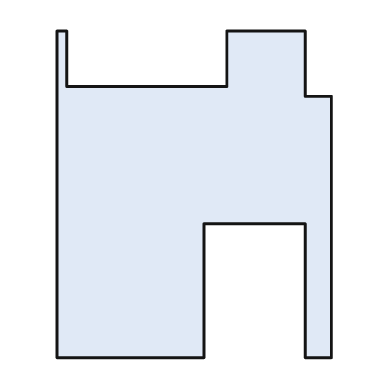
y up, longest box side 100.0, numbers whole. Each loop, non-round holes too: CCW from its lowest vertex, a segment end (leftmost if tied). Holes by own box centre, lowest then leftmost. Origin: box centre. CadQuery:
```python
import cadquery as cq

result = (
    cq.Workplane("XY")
    .moveTo(-42.0, -50.0)
    .lineTo(3.0, -50.0)
    .lineTo(3.0, -9.0)
    .lineTo(34.0, -9.0)
    .lineTo(34.0, -50.0)
    .lineTo(42.0, -50.0)
    .lineTo(42.0, 30.0)
    .lineTo(34.0, 30.0)
    .lineTo(34.0, 50.0)
    .lineTo(10.0, 50.0)
    .lineTo(10.0, 33.0)
    .lineTo(-39.0, 33.0)
    .lineTo(-39.0, 50.0)
    .lineTo(-42.0, 50.0)
    .close()
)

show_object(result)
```